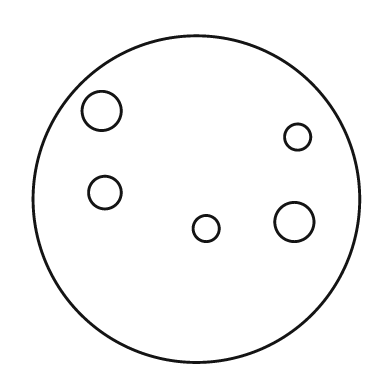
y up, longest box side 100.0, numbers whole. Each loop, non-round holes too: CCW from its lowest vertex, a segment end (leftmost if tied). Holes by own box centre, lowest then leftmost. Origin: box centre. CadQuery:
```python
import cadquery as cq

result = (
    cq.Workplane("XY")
    .moveTo(0.0, 0.0)
    .circle(50.0)
    .moveTo(3.0, -9.0)
    .circle(4.0)
    .moveTo(30.0, -7.0)
    .circle(6.0)
    .moveTo(-28.0, 2.0)
    .circle(5.0)
    .moveTo(31.0, 19.0)
    .circle(4.0)
    .moveTo(-29.0, 27.0)
    .circle(6.0)
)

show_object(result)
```